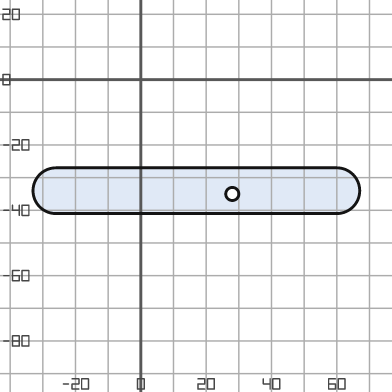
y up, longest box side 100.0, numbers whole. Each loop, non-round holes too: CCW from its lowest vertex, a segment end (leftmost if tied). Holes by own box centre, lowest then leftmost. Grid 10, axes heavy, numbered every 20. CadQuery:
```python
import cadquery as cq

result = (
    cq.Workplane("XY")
    .moveTo(-26.0, -41.0)
    .lineTo(60.0, -41.0)
    .threePointArc((67.0, -34.0), (60.0, -27.0))
    .lineTo(-26.0, -27.0)
    .threePointArc((-33.0, -34.0), (-26.0, -41.0))
    .close()
    .moveTo(28.0, -35.0)
    .circle(2.0)
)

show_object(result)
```